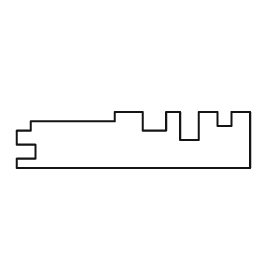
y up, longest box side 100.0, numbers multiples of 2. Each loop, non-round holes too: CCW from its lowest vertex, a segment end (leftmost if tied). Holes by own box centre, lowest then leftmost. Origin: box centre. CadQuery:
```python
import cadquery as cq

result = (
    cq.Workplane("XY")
    .moveTo(-50.0, -12.0)
    .lineTo(50.0, -12.0)
    .lineTo(50.0, 12.0)
    .lineTo(42.0, 12.0)
    .lineTo(42.0, 6.0)
    .lineTo(36.0, 6.0)
    .lineTo(36.0, 12.0)
    .lineTo(28.0, 12.0)
    .lineTo(28.0, 0.0)
    .lineTo(20.0, 0.0)
    .lineTo(20.0, 12.0)
    .lineTo(14.0, 12.0)
    .lineTo(14.0, 4.0)
    .lineTo(4.0, 4.0)
    .lineTo(4.0, 12.0)
    .lineTo(-8.0, 12.0)
    .lineTo(-8.0, 8.0)
    .lineTo(-44.0, 8.0)
    .lineTo(-44.0, 4.0)
    .lineTo(-50.0, 4.0)
    .lineTo(-50.0, -2.0)
    .lineTo(-42.0, -2.0)
    .lineTo(-42.0, -8.0)
    .lineTo(-50.0, -8.0)
    .close()
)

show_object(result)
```